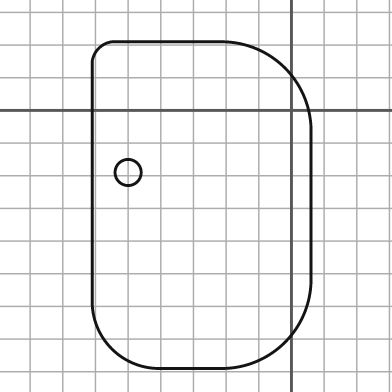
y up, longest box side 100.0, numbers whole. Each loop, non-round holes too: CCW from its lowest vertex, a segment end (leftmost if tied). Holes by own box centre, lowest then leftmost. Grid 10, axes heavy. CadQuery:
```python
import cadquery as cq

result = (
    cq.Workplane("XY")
    .moveTo(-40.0, -79.0)
    .lineTo(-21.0, -79.0)
    .threePointArc((-2.0, -71.0), (6.0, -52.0))
    .lineTo(6.0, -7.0)
    .threePointArc((-2.0, 13.0), (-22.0, 21.0))
    .lineTo(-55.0, 21.0)
    .threePointArc((-59.0, 19.0), (-61.0, 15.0))
    .lineTo(-61.0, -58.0)
    .threePointArc((-55.0, -73.0), (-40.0, -79.0))
    .close()
    .moveTo(-50.0, -19.0)
    .circle(4.0)
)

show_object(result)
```